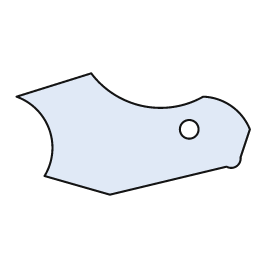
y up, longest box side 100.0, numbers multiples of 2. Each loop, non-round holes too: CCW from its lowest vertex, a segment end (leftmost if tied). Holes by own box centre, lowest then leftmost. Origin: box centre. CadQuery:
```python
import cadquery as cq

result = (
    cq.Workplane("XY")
    .moveTo(-10.0, -26.0)
    .lineTo(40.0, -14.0)
    .threePointArc((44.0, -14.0), (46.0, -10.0))
    .lineTo(50.0, 2.0)
    .threePointArc((42.0, 12.0), (30.0, 16.0))
    .threePointArc((4.0, 12.0), (-18.0, 26.0))
    .lineTo(-50.0, 16.0)
    .threePointArc((-36.0, 2.0), (-38.0, -18.0))
    .close()
    .moveTo(24.0, 2.0)
    .circle(4.0)
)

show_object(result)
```